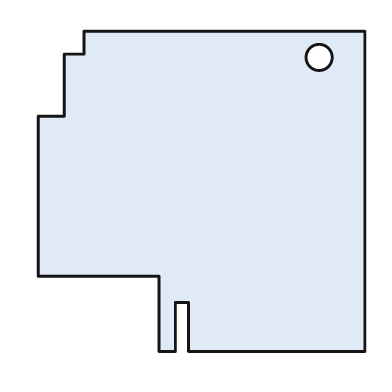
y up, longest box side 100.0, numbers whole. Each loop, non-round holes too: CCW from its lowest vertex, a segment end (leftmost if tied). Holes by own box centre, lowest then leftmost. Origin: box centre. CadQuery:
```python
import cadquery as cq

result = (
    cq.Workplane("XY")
    .moveTo(-13.0, -49.0)
    .lineTo(-8.0, -49.0)
    .lineTo(-8.0, -34.0)
    .lineTo(-4.0, -34.0)
    .lineTo(-4.0, -49.0)
    .lineTo(50.0, -49.0)
    .lineTo(50.0, 49.0)
    .lineTo(-36.0, 49.0)
    .lineTo(-36.0, 42.0)
    .lineTo(-42.0, 42.0)
    .lineTo(-42.0, 23.0)
    .lineTo(-50.0, 23.0)
    .lineTo(-50.0, -26.0)
    .lineTo(-13.0, -26.0)
    .close()
    .moveTo(36.0, 41.0)
    .circle(4.0)
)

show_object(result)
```